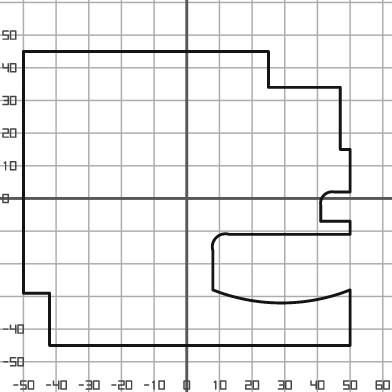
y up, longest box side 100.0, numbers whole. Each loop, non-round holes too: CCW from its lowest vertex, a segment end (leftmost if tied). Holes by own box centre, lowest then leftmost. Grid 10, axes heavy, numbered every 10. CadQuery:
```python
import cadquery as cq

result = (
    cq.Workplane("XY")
    .moveTo(-42.0, -45.0)
    .lineTo(50.0, -45.0)
    .lineTo(50.0, -28.0)
    .threePointArc((29.0, -32.0), (8.0, -28.0))
    .lineTo(8.0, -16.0)
    .threePointArc((9.0, -12.0), (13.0, -11.0))
    .lineTo(50.0, -11.0)
    .lineTo(50.0, -7.0)
    .lineTo(41.0, -7.0)
    .lineTo(41.0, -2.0)
    .threePointArc((42.0, 1.0), (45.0, 2.0))
    .lineTo(50.0, 2.0)
    .lineTo(50.0, 15.0)
    .lineTo(47.0, 15.0)
    .lineTo(47.0, 34.0)
    .lineTo(25.0, 34.0)
    .lineTo(25.0, 45.0)
    .lineTo(-50.0, 45.0)
    .lineTo(-50.0, -29.0)
    .lineTo(-42.0, -29.0)
    .close()
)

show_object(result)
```